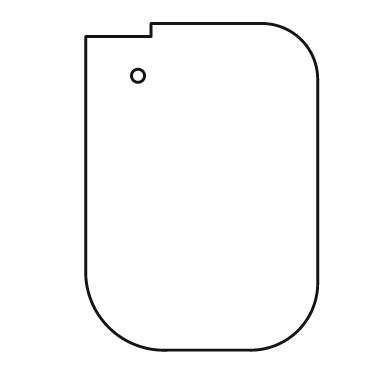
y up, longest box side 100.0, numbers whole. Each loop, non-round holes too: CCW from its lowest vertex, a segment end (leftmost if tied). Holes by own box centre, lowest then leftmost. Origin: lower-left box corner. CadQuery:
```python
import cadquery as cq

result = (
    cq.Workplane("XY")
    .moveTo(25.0, 0.0)
    .lineTo(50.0, 0.0)
    .threePointArc((65.0, 6.0), (71.0, 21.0))
    .lineTo(71.0, 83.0)
    .threePointArc((66.0, 95.0), (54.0, 100.0))
    .lineTo(20.0, 100.0)
    .lineTo(20.0, 96.0)
    .lineTo(0.0, 96.0)
    .lineTo(0.0, 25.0)
    .threePointArc((7.0, 7.0), (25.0, 0.0))
    .close()
    .moveTo(16.0, 84.0)
    .circle(2.0)
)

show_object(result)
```